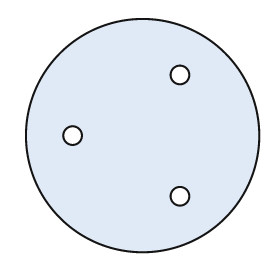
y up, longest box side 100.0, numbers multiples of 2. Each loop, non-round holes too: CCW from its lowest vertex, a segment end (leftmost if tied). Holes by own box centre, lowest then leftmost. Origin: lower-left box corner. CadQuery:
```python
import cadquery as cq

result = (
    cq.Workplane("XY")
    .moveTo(50.0, 50.0)
    .circle(50.0)
    .moveTo(66.0, 24.0)
    .circle(4.0)
    .moveTo(20.0, 50.0)
    .circle(4.0)
    .moveTo(66.0, 76.0)
    .circle(4.0)
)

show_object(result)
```